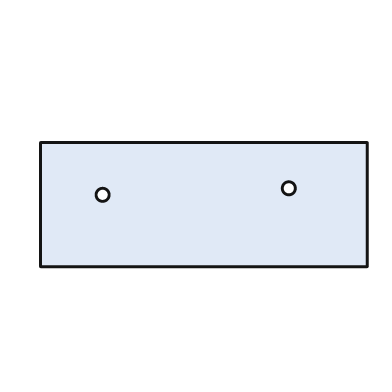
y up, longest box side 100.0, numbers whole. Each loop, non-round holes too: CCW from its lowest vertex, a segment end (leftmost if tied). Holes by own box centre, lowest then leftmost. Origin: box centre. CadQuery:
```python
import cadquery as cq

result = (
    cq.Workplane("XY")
    .moveTo(-50.0, -19.0)
    .lineTo(50.0, -19.0)
    .lineTo(50.0, 19.0)
    .lineTo(-50.0, 19.0)
    .close()
    .moveTo(-31.0, 3.0)
    .circle(2.0)
    .moveTo(26.0, 5.0)
    .circle(2.0)
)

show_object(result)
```